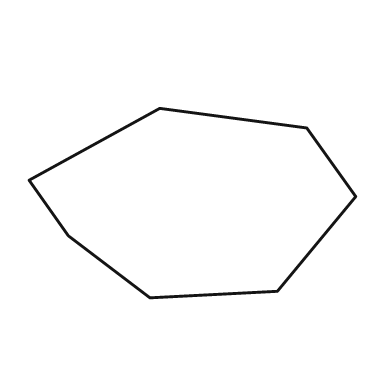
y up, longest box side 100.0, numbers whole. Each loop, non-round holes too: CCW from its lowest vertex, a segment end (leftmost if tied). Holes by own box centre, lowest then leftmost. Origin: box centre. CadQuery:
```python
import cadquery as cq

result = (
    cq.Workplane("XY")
    .moveTo(-13.0, -29.0)
    .lineTo(26.0, -27.0)
    .lineTo(50.0, 2.0)
    .lineTo(35.0, 23.0)
    .lineTo(-10.0, 29.0)
    .lineTo(-50.0, 7.0)
    .lineTo(-38.0, -10.0)
    .close()
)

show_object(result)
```